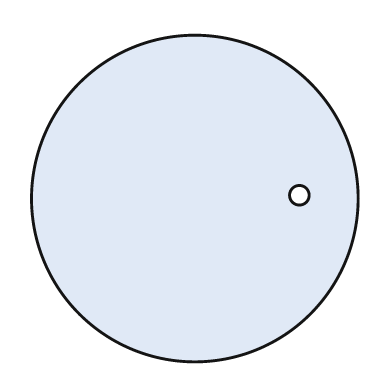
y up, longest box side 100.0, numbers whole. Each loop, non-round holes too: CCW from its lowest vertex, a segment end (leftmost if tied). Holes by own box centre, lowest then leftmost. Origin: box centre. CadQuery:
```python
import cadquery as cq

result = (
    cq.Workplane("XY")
    .moveTo(0.0, 0.0)
    .circle(50.0)
    .moveTo(32.0, 1.0)
    .circle(3.0)
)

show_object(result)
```